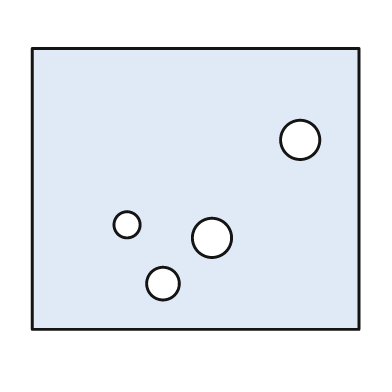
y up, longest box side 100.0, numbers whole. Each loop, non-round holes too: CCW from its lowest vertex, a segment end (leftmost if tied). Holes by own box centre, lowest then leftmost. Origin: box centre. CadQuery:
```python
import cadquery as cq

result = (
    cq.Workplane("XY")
    .moveTo(-50.0, -43.0)
    .lineTo(50.0, -43.0)
    .lineTo(50.0, 43.0)
    .lineTo(-50.0, 43.0)
    .close()
    .moveTo(-10.0, -29.0)
    .circle(5.0)
    .moveTo(5.0, -15.0)
    .circle(6.0)
    .moveTo(-21.0, -11.0)
    .circle(4.0)
    .moveTo(32.0, 15.0)
    .circle(6.0)
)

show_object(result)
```